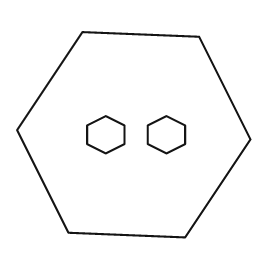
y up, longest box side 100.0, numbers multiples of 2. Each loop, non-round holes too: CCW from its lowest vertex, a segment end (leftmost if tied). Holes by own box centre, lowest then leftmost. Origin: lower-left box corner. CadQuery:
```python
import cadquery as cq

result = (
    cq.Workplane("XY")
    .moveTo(72.0, 0.0)
    .lineTo(100.0, 42.0)
    .lineTo(78.0, 86.0)
    .lineTo(28.0, 88.0)
    .lineTo(0.0, 46.0)
    .lineTo(22.0, 2.0)
    .close()
    .moveTo(38.0, 36.0)
    .lineTo(46.0, 40.0)
    .lineTo(46.0, 48.0)
    .lineTo(38.0, 52.0)
    .lineTo(30.0, 48.0)
    .lineTo(30.0, 40.0)
    .close()
    .moveTo(64.0, 36.0)
    .lineTo(72.0, 40.0)
    .lineTo(72.0, 48.0)
    .lineTo(64.0, 52.0)
    .lineTo(56.0, 48.0)
    .lineTo(56.0, 40.0)
    .close()
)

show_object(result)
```